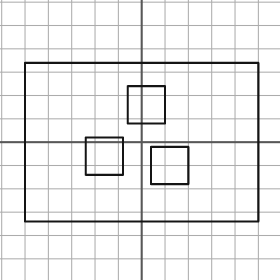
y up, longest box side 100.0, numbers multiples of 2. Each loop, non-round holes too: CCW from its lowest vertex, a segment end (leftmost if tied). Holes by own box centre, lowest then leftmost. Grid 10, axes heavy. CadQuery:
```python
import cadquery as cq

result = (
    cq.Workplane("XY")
    .moveTo(-50.0, -34.0)
    .lineTo(50.0, -34.0)
    .lineTo(50.0, 34.0)
    .lineTo(-50.0, 34.0)
    .close()
    .moveTo(4.0, -18.0)
    .lineTo(20.0, -18.0)
    .lineTo(20.0, -2.0)
    .lineTo(4.0, -2.0)
    .close()
    .moveTo(-24.0, -14.0)
    .lineTo(-8.0, -14.0)
    .lineTo(-8.0, 2.0)
    .lineTo(-24.0, 2.0)
    .close()
    .moveTo(-6.0, 8.0)
    .lineTo(10.0, 8.0)
    .lineTo(10.0, 24.0)
    .lineTo(-6.0, 24.0)
    .close()
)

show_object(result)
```